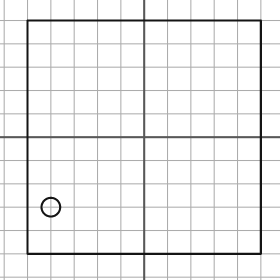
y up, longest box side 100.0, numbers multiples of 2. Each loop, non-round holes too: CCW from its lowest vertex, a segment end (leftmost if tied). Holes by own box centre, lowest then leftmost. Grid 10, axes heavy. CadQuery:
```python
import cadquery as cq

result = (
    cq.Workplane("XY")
    .moveTo(-50.0, -50.0)
    .lineTo(50.0, -50.0)
    .lineTo(50.0, 50.0)
    .lineTo(-50.0, 50.0)
    .close()
    .moveTo(-40.0, -30.0)
    .circle(4.0)
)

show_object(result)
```